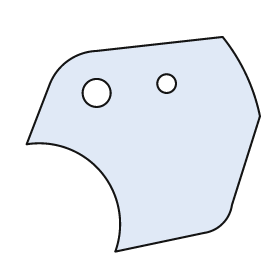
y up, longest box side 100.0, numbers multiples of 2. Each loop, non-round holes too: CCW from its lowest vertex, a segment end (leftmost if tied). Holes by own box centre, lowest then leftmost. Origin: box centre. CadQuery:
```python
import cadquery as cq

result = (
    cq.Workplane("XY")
    .moveTo(-12.0, -46.0)
    .lineTo(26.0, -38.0)
    .threePointArc((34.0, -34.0), (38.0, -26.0))
    .lineTo(50.0, 12.0)
    .threePointArc((44.0, 30.0), (34.0, 46.0))
    .lineTo(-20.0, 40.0)
    .threePointArc((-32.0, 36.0), (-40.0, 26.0))
    .lineTo(-50.0, 0.0)
    .threePointArc((-18.0, -12.0), (-12.0, -46.0))
    .close()
    .moveTo(-20.0, 22.0)
    .circle(6.0)
    .moveTo(10.0, 26.0)
    .circle(4.0)
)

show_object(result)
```